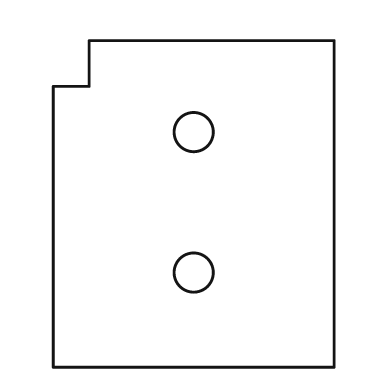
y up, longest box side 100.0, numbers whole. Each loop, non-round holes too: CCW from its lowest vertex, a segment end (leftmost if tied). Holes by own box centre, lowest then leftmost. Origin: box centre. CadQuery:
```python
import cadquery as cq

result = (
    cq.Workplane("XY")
    .moveTo(-43.0, -50.0)
    .lineTo(43.0, -50.0)
    .lineTo(43.0, 50.0)
    .lineTo(-32.0, 50.0)
    .lineTo(-32.0, 36.0)
    .lineTo(-43.0, 36.0)
    .close()
    .moveTo(0.0, -21.0)
    .circle(6.0)
    .moveTo(0.0, 22.0)
    .circle(6.0)
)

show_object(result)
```